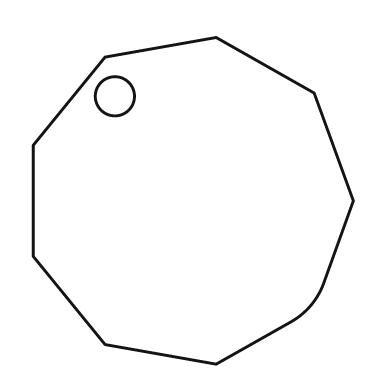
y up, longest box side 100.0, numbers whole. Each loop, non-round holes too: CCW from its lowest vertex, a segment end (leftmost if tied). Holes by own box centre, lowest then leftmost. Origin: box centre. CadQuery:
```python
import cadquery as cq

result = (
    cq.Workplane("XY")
    .moveTo(7.0, -50.0)
    .lineTo(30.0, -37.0)
    .threePointArc((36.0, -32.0), (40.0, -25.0))
    .lineTo(49.0, 0.0)
    .lineTo(37.0, 33.0)
    .lineTo(7.0, 50.0)
    .lineTo(-27.0, 44.0)
    .lineTo(-49.0, 17.0)
    .lineTo(-49.0, -17.0)
    .lineTo(-27.0, -44.0)
    .close()
    .moveTo(-24.0, 32.0)
    .circle(6.0)
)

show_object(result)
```